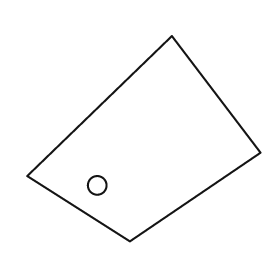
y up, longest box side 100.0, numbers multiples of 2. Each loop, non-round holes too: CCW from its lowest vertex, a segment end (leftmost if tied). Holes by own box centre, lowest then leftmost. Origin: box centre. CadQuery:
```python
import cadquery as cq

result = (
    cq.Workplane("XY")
    .moveTo(-6.0, -44.0)
    .lineTo(50.0, -6.0)
    .lineTo(12.0, 44.0)
    .lineTo(-50.0, -16.0)
    .close()
    .moveTo(-20.0, -20.0)
    .circle(4.0)
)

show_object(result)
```